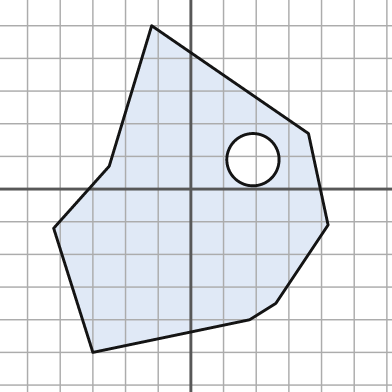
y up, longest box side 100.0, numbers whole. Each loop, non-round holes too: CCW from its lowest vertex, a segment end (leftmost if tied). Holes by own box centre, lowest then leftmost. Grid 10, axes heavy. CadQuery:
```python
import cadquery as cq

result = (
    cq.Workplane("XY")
    .moveTo(-30.0, -50.0)
    .lineTo(18.0, -40.0)
    .lineTo(26.0, -35.0)
    .lineTo(42.0, -11.0)
    .lineTo(36.0, 17.0)
    .lineTo(-12.0, 50.0)
    .lineTo(-25.0, 7.0)
    .lineTo(-42.0, -12.0)
    .close()
    .moveTo(19.0, 9.0)
    .circle(8.0)
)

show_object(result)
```